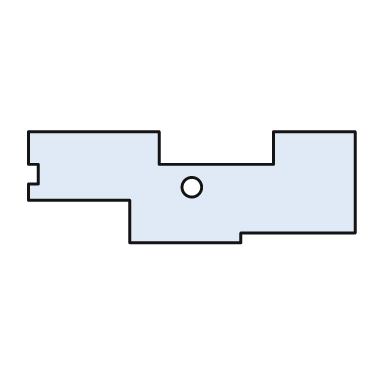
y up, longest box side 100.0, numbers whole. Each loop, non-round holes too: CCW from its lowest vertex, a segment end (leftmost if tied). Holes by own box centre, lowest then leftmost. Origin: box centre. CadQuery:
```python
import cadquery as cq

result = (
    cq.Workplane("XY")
    .moveTo(-19.0, -17.0)
    .lineTo(15.0, -17.0)
    .lineTo(15.0, -14.0)
    .lineTo(50.0, -14.0)
    .lineTo(50.0, 17.0)
    .lineTo(25.0, 17.0)
    .lineTo(25.0, 7.0)
    .lineTo(-10.0, 7.0)
    .lineTo(-10.0, 17.0)
    .lineTo(-50.0, 17.0)
    .lineTo(-50.0, 7.0)
    .lineTo(-47.0, 7.0)
    .lineTo(-47.0, 1.0)
    .lineTo(-50.0, 1.0)
    .lineTo(-50.0, -4.0)
    .lineTo(-19.0, -4.0)
    .close()
    .moveTo(0.0, 0.0)
    .circle(3.0)
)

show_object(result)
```